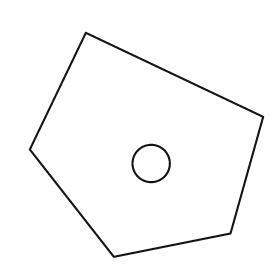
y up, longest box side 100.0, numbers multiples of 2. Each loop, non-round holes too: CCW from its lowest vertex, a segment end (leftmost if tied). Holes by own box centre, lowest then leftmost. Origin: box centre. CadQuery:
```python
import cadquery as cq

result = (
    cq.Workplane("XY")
    .moveTo(-14.0, -48.0)
    .lineTo(36.0, -38.0)
    .lineTo(50.0, 12.0)
    .lineTo(-26.0, 48.0)
    .lineTo(-50.0, -2.0)
    .close()
    .moveTo(2.0, -8.0)
    .circle(8.0)
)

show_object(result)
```